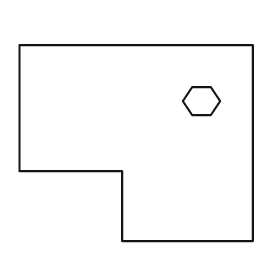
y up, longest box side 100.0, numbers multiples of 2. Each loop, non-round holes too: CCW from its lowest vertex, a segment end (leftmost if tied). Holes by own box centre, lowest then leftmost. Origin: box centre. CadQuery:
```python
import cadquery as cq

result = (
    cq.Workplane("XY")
    .moveTo(-6.0, -42.0)
    .lineTo(50.0, -42.0)
    .lineTo(50.0, 42.0)
    .lineTo(-50.0, 42.0)
    .lineTo(-50.0, -12.0)
    .lineTo(-6.0, -12.0)
    .close()
    .moveTo(24.0, 12.0)
    .lineTo(32.0, 12.0)
    .lineTo(36.0, 18.0)
    .lineTo(32.0, 24.0)
    .lineTo(24.0, 24.0)
    .lineTo(20.0, 18.0)
    .close()
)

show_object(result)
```